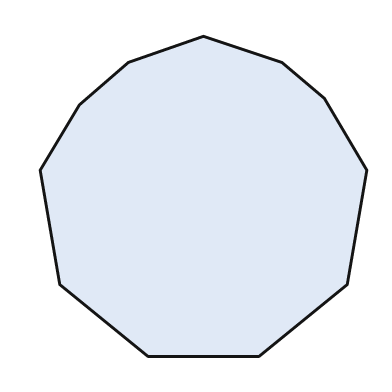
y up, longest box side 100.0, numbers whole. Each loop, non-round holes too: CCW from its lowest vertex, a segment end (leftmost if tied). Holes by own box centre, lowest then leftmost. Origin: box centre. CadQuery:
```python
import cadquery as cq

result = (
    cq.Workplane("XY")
    .moveTo(-17.0, -49.0)
    .lineTo(17.0, -49.0)
    .lineTo(44.0, -27.0)
    .lineTo(50.0, 8.0)
    .lineTo(37.0, 30.0)
    .lineTo(24.0, 41.0)
    .lineTo(0.0, 49.0)
    .lineTo(-23.0, 41.0)
    .lineTo(-38.0, 28.0)
    .lineTo(-50.0, 8.0)
    .lineTo(-44.0, -27.0)
    .close()
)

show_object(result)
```